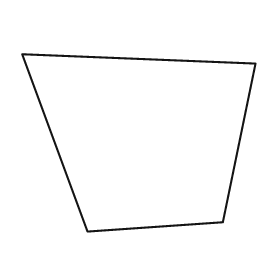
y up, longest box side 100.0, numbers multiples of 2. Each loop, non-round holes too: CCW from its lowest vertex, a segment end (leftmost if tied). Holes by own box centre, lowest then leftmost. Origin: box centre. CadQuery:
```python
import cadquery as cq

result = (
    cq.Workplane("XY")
    .moveTo(-22.0, -38.0)
    .lineTo(36.0, -34.0)
    .lineTo(50.0, 34.0)
    .lineTo(-50.0, 38.0)
    .close()
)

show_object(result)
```